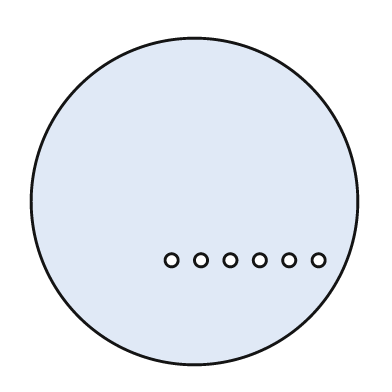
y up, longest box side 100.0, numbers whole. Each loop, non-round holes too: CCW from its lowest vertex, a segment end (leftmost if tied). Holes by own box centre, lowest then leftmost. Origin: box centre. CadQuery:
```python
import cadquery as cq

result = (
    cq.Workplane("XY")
    .moveTo(0.0, 0.0)
    .circle(50.0)
    .moveTo(-7.0, -18.0)
    .circle(2.0)
    .moveTo(2.0, -18.0)
    .circle(2.0)
    .moveTo(11.0, -18.0)
    .circle(2.0)
    .moveTo(20.0, -18.0)
    .circle(2.0)
    .moveTo(29.0, -18.0)
    .circle(2.0)
    .moveTo(38.0, -18.0)
    .circle(2.0)
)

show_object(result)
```